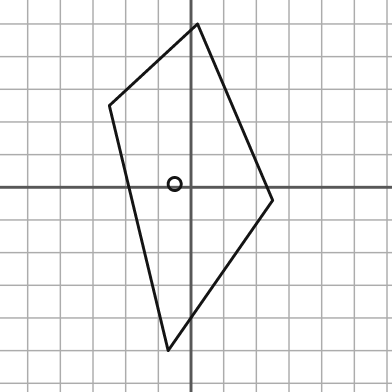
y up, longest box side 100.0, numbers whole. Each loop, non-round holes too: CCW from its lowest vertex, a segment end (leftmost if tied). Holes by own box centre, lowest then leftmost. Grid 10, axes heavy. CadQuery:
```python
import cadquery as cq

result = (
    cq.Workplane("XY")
    .moveTo(-7.0, -50.0)
    .lineTo(25.0, -4.0)
    .lineTo(2.0, 50.0)
    .lineTo(-25.0, 25.0)
    .close()
    .moveTo(-5.0, 1.0)
    .circle(2.0)
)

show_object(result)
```